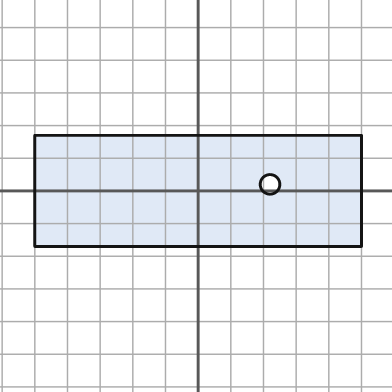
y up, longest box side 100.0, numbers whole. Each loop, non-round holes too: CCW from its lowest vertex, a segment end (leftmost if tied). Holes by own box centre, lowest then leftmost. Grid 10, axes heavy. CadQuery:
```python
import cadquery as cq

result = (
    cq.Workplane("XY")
    .moveTo(-50.0, -17.0)
    .lineTo(50.0, -17.0)
    .lineTo(50.0, 17.0)
    .lineTo(-50.0, 17.0)
    .close()
    .moveTo(22.0, 2.0)
    .circle(3.0)
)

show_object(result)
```